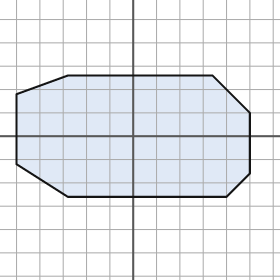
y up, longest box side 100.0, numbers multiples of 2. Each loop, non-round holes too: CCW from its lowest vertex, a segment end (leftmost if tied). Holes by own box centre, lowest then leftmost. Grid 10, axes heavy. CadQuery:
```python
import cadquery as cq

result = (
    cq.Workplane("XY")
    .moveTo(-28.0, -26.0)
    .lineTo(40.0, -26.0)
    .lineTo(50.0, -16.0)
    .lineTo(50.0, 10.0)
    .lineTo(34.0, 26.0)
    .lineTo(-28.0, 26.0)
    .lineTo(-50.0, 18.0)
    .lineTo(-50.0, -12.0)
    .close()
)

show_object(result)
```